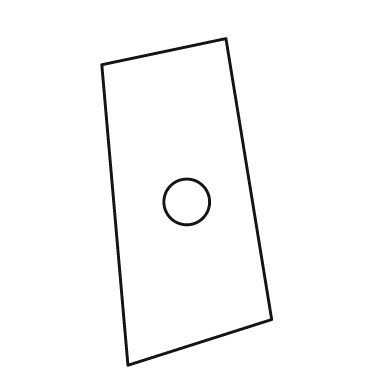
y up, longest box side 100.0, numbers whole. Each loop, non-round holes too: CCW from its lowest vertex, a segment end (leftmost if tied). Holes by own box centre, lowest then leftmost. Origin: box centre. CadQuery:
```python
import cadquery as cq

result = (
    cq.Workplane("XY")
    .moveTo(-18.0, -50.0)
    .lineTo(26.0, -36.0)
    .lineTo(12.0, 50.0)
    .lineTo(-26.0, 42.0)
    .close()
    .moveTo(0.0, 0.0)
    .circle(7.0)
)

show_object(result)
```